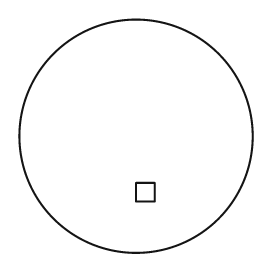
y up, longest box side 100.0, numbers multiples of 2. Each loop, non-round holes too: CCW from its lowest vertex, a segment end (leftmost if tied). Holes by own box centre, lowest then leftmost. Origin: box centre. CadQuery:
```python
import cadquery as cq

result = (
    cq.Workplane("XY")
    .moveTo(0.0, 0.0)
    .circle(50.0)
    .moveTo(0.0, -28.0)
    .lineTo(8.0, -28.0)
    .lineTo(8.0, -20.0)
    .lineTo(0.0, -20.0)
    .close()
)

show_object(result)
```